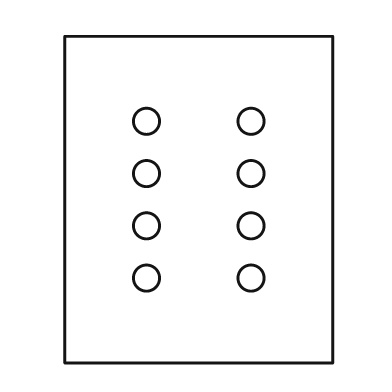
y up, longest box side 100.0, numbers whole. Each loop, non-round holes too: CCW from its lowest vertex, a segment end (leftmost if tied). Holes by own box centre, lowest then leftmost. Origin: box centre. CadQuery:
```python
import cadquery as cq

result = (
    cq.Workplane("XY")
    .moveTo(-41.0, -50.0)
    .lineTo(41.0, -50.0)
    .lineTo(41.0, 50.0)
    .lineTo(-41.0, 50.0)
    .close()
    .moveTo(-16.0, -24.0)
    .circle(4.0)
    .moveTo(16.0, -24.0)
    .circle(4.0)
    .moveTo(-16.0, -8.0)
    .circle(4.0)
    .moveTo(16.0, -8.0)
    .circle(4.0)
    .moveTo(-16.0, 8.0)
    .circle(4.0)
    .moveTo(16.0, 8.0)
    .circle(4.0)
    .moveTo(-16.0, 24.0)
    .circle(4.0)
    .moveTo(16.0, 24.0)
    .circle(4.0)
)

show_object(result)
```